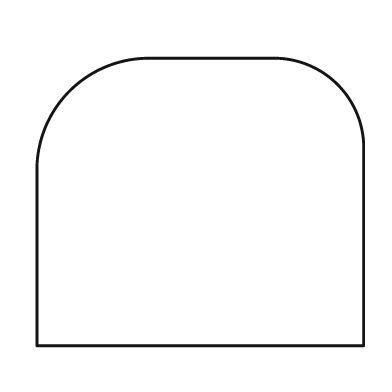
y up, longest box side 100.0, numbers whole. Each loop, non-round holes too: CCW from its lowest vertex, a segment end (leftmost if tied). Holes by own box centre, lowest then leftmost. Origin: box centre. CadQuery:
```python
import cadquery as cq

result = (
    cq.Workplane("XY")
    .moveTo(-50.0, -44.0)
    .lineTo(50.0, -44.0)
    .lineTo(50.0, 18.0)
    .threePointArc((42.0, 36.0), (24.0, 44.0))
    .lineTo(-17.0, 44.0)
    .threePointArc((-40.0, 34.0), (-50.0, 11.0))
    .close()
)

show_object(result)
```